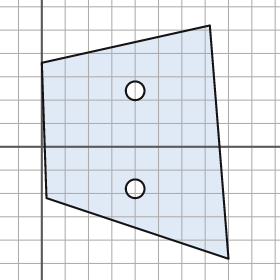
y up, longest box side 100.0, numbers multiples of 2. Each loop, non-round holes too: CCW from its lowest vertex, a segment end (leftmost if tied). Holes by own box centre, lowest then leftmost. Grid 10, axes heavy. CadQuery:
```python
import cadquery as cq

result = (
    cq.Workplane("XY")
    .moveTo(80.0, -48.0)
    .lineTo(72.0, 52.0)
    .lineTo(0.0, 36.0)
    .lineTo(2.0, -22.0)
    .close()
    .moveTo(40.0, -18.0)
    .circle(4.0)
    .moveTo(40.0, 24.0)
    .circle(4.0)
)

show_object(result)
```